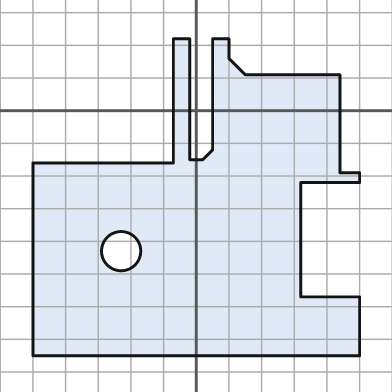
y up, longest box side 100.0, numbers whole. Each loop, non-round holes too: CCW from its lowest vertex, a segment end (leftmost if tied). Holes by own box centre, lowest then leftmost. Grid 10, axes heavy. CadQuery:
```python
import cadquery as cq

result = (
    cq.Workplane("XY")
    .moveTo(-50.0, -75.0)
    .lineTo(50.0, -75.0)
    .lineTo(50.0, -57.0)
    .lineTo(32.0, -57.0)
    .lineTo(32.0, -22.0)
    .lineTo(50.0, -22.0)
    .lineTo(50.0, -19.0)
    .lineTo(44.0, -19.0)
    .lineTo(44.0, 11.0)
    .lineTo(15.0, 11.0)
    .lineTo(10.0, 16.0)
    .lineTo(10.0, 22.0)
    .lineTo(5.0, 22.0)
    .lineTo(5.0, -12.0)
    .lineTo(2.0, -15.0)
    .lineTo(-2.0, -15.0)
    .lineTo(-2.0, 22.0)
    .lineTo(-7.0, 22.0)
    .lineTo(-7.0, -16.0)
    .lineTo(-50.0, -16.0)
    .close()
    .moveTo(-23.0, -43.0)
    .circle(6.0)
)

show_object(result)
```